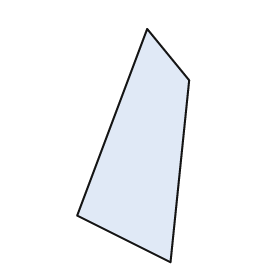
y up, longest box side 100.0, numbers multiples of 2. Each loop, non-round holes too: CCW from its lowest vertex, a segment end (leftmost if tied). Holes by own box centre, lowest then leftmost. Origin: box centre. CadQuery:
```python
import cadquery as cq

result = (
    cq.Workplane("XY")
    .moveTo(16.0, -50.0)
    .lineTo(24.0, 28.0)
    .lineTo(6.0, 50.0)
    .lineTo(-24.0, -30.0)
    .close()
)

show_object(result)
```